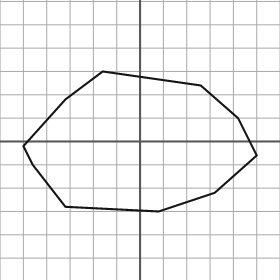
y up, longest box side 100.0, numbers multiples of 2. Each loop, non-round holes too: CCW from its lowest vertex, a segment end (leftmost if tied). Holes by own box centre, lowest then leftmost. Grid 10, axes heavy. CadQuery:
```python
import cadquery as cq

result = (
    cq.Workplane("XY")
    .moveTo(8.0, -30.0)
    .lineTo(32.0, -22.0)
    .lineTo(50.0, -6.0)
    .lineTo(42.0, 10.0)
    .lineTo(26.0, 24.0)
    .lineTo(-16.0, 30.0)
    .lineTo(-32.0, 18.0)
    .lineTo(-50.0, -2.0)
    .lineTo(-46.0, -10.0)
    .lineTo(-32.0, -28.0)
    .close()
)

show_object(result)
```